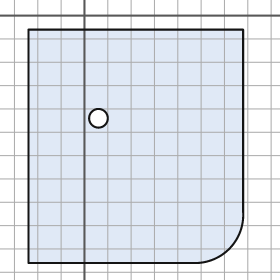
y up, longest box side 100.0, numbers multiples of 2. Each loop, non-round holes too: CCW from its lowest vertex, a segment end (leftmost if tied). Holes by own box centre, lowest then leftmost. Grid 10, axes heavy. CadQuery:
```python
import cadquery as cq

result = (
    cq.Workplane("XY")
    .moveTo(-24.0, -106.0)
    .lineTo(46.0, -106.0)
    .threePointArc((62.0, -100.0), (68.0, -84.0))
    .lineTo(68.0, -6.0)
    .lineTo(-24.0, -6.0)
    .close()
    .moveTo(6.0, -44.0)
    .circle(4.0)
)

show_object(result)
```